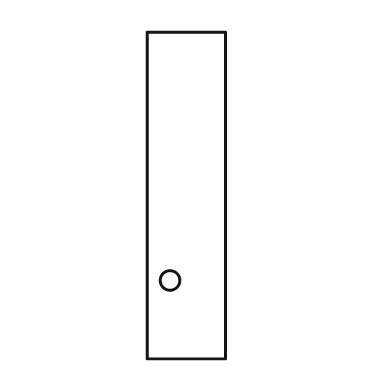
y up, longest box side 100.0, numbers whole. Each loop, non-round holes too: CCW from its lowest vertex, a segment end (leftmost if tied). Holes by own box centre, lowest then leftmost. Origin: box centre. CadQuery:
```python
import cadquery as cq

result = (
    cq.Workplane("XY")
    .moveTo(-12.0, -50.0)
    .lineTo(12.0, -50.0)
    .lineTo(12.0, 50.0)
    .lineTo(-12.0, 50.0)
    .close()
    .moveTo(-5.0, -26.0)
    .circle(3.0)
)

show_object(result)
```